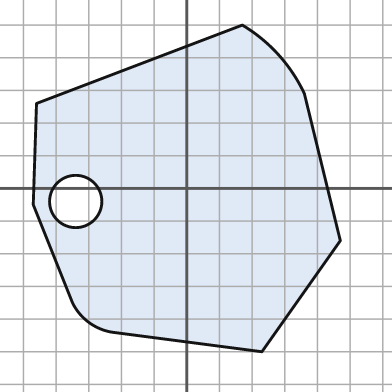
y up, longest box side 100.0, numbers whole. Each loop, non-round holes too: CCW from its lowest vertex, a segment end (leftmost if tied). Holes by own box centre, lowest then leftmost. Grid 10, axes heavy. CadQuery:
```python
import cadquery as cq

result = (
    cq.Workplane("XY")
    .moveTo(23.0, -50.0)
    .lineTo(47.0, -16.0)
    .lineTo(36.0, 29.0)
    .threePointArc((28.0, 41.0), (17.0, 50.0))
    .lineTo(-46.0, 26.0)
    .lineTo(-47.0, -5.0)
    .lineTo(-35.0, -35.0)
    .threePointArc((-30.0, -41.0), (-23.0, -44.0))
    .close()
    .moveTo(-34.0, -4.0)
    .circle(8.0)
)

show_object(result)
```